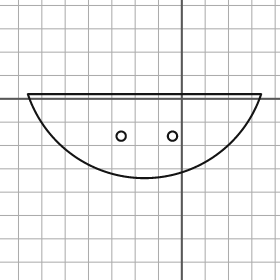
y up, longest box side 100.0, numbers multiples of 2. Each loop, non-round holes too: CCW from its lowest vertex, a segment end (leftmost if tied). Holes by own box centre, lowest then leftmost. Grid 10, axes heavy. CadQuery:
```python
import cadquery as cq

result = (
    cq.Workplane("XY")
    .moveTo(-66.0, 2.0)
    .threePointArc((-16.0, -34.0), (34.0, 2.0))
    .close()
    .moveTo(-26.0, -16.0)
    .circle(2.0)
    .moveTo(-4.0, -16.0)
    .circle(2.0)
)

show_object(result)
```